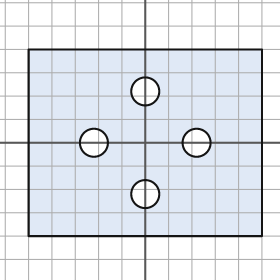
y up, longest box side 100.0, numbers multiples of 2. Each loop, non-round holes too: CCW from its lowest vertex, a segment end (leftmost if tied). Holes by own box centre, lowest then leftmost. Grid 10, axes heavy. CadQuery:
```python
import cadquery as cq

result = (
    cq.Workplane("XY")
    .moveTo(-50.0, -40.0)
    .lineTo(50.0, -40.0)
    .lineTo(50.0, 40.0)
    .lineTo(-50.0, 40.0)
    .close()
    .moveTo(0.0, -22.0)
    .circle(6.0)
    .moveTo(-22.0, 0.0)
    .circle(6.0)
    .moveTo(22.0, 0.0)
    .circle(6.0)
    .moveTo(0.0, 22.0)
    .circle(6.0)
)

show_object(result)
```